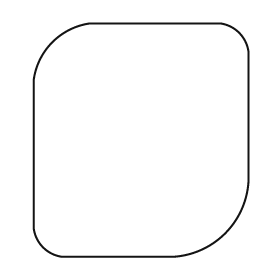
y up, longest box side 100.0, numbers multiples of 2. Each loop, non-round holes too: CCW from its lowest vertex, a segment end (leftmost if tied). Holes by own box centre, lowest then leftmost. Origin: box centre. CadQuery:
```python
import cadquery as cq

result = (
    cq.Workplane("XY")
    .moveTo(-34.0, -50.0)
    .lineTo(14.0, -50.0)
    .threePointArc((36.0, -40.0), (46.0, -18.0))
    .lineTo(46.0, 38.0)
    .threePointArc((42.0, 46.0), (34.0, 50.0))
    .lineTo(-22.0, 50.0)
    .threePointArc((-38.0, 42.0), (-46.0, 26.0))
    .lineTo(-46.0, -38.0)
    .threePointArc((-42.0, -46.0), (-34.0, -50.0))
    .close()
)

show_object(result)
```